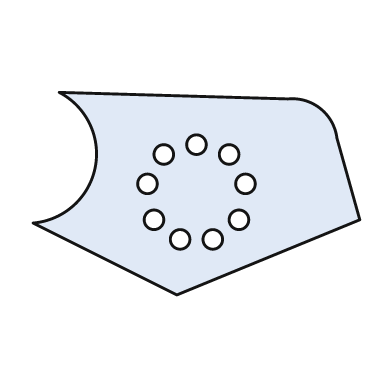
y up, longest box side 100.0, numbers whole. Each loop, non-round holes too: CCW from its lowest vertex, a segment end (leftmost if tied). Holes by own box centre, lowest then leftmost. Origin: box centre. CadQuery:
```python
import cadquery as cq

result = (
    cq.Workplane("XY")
    .moveTo(-6.0, -31.0)
    .lineTo(50.0, -8.0)
    .lineTo(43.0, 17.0)
    .threePointArc((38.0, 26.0), (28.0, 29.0))
    .lineTo(-42.0, 31.0)
    .threePointArc((-31.0, 8.0), (-50.0, -9.0))
    .close()
    .moveTo(-5.0, -14.0)
    .circle(3.0)
    .moveTo(5.0, -14.0)
    .circle(3.0)
    .moveTo(-13.0, -8.0)
    .circle(3.0)
    .moveTo(13.0, -8.0)
    .circle(3.0)
    .moveTo(-15.0, 3.0)
    .circle(3.0)
    .moveTo(15.0, 3.0)
    .circle(3.0)
    .moveTo(-10.0, 12.0)
    .circle(3.0)
    .moveTo(10.0, 12.0)
    .circle(3.0)
    .moveTo(0.0, 15.0)
    .circle(3.0)
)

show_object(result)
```